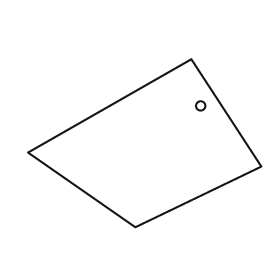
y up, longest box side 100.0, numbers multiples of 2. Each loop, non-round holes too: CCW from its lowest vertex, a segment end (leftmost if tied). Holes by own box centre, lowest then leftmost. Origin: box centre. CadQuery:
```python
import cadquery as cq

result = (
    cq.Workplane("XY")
    .moveTo(-4.0, -36.0)
    .lineTo(50.0, -10.0)
    .lineTo(20.0, 36.0)
    .lineTo(-50.0, -4.0)
    .close()
    .moveTo(24.0, 16.0)
    .circle(2.0)
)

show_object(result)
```